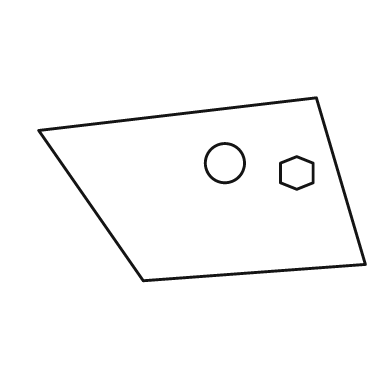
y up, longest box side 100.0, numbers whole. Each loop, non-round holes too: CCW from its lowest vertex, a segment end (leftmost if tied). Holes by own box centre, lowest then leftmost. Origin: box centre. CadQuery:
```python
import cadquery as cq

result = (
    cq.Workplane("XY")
    .moveTo(-18.0, -28.0)
    .lineTo(50.0, -23.0)
    .lineTo(35.0, 28.0)
    .lineTo(-50.0, 18.0)
    .close()
    .moveTo(29.0, 0.0)
    .lineTo(34.0, 2.0)
    .lineTo(34.0, 8.0)
    .lineTo(29.0, 10.0)
    .lineTo(24.0, 8.0)
    .lineTo(24.0, 2.0)
    .close()
    .moveTo(7.0, 8.0)
    .circle(6.0)
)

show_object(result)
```